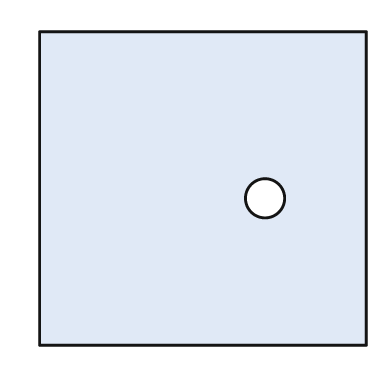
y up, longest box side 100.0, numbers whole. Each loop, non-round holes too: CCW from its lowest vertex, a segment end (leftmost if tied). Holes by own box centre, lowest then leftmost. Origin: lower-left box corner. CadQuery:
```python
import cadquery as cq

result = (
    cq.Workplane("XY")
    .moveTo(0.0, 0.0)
    .lineTo(100.0, 0.0)
    .lineTo(100.0, 96.0)
    .lineTo(0.0, 96.0)
    .close()
    .moveTo(69.0, 45.0)
    .circle(6.0)
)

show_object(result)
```